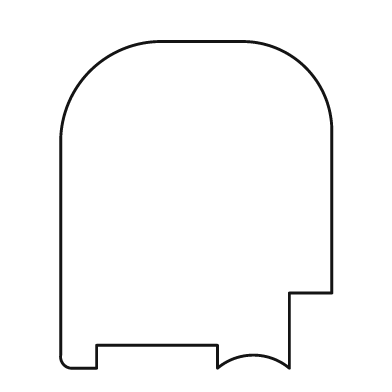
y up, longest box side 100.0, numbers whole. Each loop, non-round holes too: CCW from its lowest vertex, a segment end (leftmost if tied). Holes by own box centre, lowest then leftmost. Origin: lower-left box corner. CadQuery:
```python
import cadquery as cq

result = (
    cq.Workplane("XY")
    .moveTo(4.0, 0.0)
    .lineTo(11.0, 0.0)
    .lineTo(11.0, 7.0)
    .lineTo(48.0, 7.0)
    .lineTo(48.0, 0.0)
    .threePointArc((59.0, 4.0), (70.0, 0.0))
    .lineTo(70.0, 23.0)
    .lineTo(83.0, 23.0)
    .lineTo(83.0, 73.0)
    .threePointArc((75.0, 92.0), (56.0, 100.0))
    .lineTo(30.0, 100.0)
    .threePointArc((9.0, 91.0), (0.0, 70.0))
    .lineTo(0.0, 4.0)
    .threePointArc((1.0, 1.0), (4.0, 0.0))
    .close()
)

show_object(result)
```